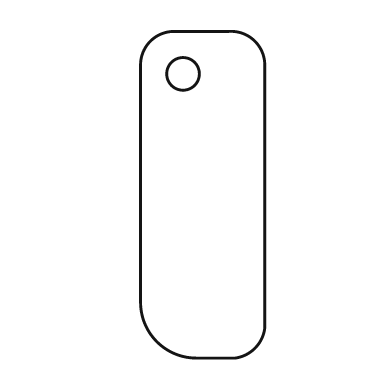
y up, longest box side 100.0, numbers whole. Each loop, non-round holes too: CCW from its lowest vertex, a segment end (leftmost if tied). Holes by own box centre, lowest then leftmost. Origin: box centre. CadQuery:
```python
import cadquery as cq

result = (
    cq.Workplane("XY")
    .moveTo(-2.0, -50.0)
    .lineTo(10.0, -50.0)
    .threePointArc((16.0, -47.0), (19.0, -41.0))
    .lineTo(19.0, 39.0)
    .threePointArc((16.0, 47.0), (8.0, 50.0))
    .lineTo(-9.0, 50.0)
    .threePointArc((-16.0, 47.0), (-19.0, 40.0))
    .lineTo(-19.0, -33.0)
    .threePointArc((-14.0, -45.0), (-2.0, -50.0))
    .close()
    .moveTo(-6.0, 37.0)
    .circle(5.0)
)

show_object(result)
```